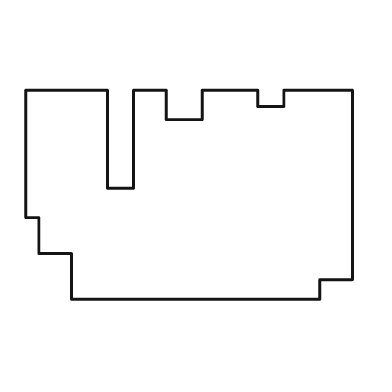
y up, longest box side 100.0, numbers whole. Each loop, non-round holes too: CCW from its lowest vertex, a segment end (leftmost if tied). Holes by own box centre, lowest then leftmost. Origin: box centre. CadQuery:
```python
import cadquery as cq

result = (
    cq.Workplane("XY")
    .moveTo(-36.0, -32.0)
    .lineTo(40.0, -32.0)
    .lineTo(40.0, -26.0)
    .lineTo(50.0, -26.0)
    .lineTo(50.0, 32.0)
    .lineTo(29.0, 32.0)
    .lineTo(29.0, 27.0)
    .lineTo(21.0, 27.0)
    .lineTo(21.0, 32.0)
    .lineTo(4.0, 32.0)
    .lineTo(4.0, 23.0)
    .lineTo(-7.0, 23.0)
    .lineTo(-7.0, 32.0)
    .lineTo(-17.0, 32.0)
    .lineTo(-17.0, 2.0)
    .lineTo(-25.0, 2.0)
    .lineTo(-25.0, 32.0)
    .lineTo(-50.0, 32.0)
    .lineTo(-50.0, -7.0)
    .lineTo(-46.0, -7.0)
    .lineTo(-46.0, -18.0)
    .lineTo(-36.0, -18.0)
    .close()
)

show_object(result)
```